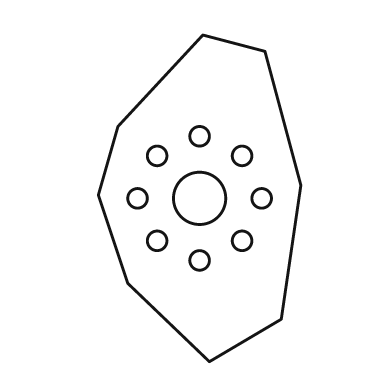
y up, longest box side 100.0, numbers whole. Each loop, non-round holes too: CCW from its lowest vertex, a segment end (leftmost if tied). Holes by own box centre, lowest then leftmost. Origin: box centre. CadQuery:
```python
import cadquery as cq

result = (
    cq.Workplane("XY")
    .moveTo(3.0, -50.0)
    .lineTo(25.0, -37.0)
    .lineTo(31.0, 4.0)
    .lineTo(20.0, 45.0)
    .lineTo(1.0, 50.0)
    .lineTo(-25.0, 22.0)
    .lineTo(-31.0, 1.0)
    .lineTo(-22.0, -26.0)
    .close()
    .moveTo(0.0, -19.0)
    .circle(3.0)
    .moveTo(-13.0, -13.0)
    .circle(3.0)
    .moveTo(13.0, -13.0)
    .circle(3.0)
    .moveTo(-19.0, 0.0)
    .circle(3.0)
    .moveTo(0.0, 0.0)
    .circle(8.0)
    .moveTo(19.0, 0.0)
    .circle(3.0)
    .moveTo(-13.0, 13.0)
    .circle(3.0)
    .moveTo(13.0, 13.0)
    .circle(3.0)
    .moveTo(0.0, 19.0)
    .circle(3.0)
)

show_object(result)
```